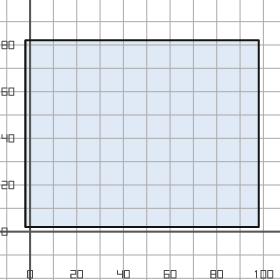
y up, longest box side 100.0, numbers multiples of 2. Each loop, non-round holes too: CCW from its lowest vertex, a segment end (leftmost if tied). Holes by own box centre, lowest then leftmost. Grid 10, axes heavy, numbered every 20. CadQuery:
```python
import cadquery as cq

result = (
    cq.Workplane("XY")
    .moveTo(-2.0, 2.0)
    .lineTo(98.0, 2.0)
    .lineTo(98.0, 82.0)
    .lineTo(-2.0, 82.0)
    .close()
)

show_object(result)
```